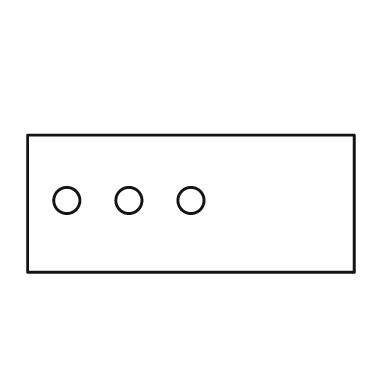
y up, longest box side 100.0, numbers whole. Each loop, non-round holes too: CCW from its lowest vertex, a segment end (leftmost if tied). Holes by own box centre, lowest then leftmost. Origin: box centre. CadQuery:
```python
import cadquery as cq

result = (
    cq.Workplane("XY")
    .moveTo(-50.0, -21.0)
    .lineTo(50.0, -21.0)
    .lineTo(50.0, 21.0)
    .lineTo(-50.0, 21.0)
    .close()
    .moveTo(-38.0, 1.0)
    .circle(4.0)
    .moveTo(-19.0, 1.0)
    .circle(4.0)
    .moveTo(0.0, 1.0)
    .circle(4.0)
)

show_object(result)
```